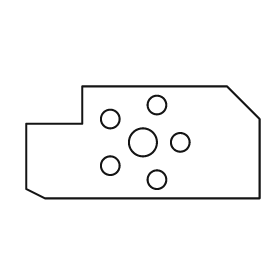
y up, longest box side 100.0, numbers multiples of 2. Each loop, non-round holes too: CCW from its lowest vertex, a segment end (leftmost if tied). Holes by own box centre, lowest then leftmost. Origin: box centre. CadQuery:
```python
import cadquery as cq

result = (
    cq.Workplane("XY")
    .moveTo(-42.0, -24.0)
    .lineTo(50.0, -24.0)
    .lineTo(50.0, 10.0)
    .lineTo(36.0, 24.0)
    .lineTo(-26.0, 24.0)
    .lineTo(-26.0, 8.0)
    .lineTo(-50.0, 8.0)
    .lineTo(-50.0, -20.0)
    .close()
    .moveTo(6.0, -16.0)
    .circle(4.0)
    .moveTo(-14.0, -10.0)
    .circle(4.0)
    .moveTo(0.0, 0.0)
    .circle(6.0)
    .moveTo(16.0, 0.0)
    .circle(4.0)
    .moveTo(-14.0, 10.0)
    .circle(4.0)
    .moveTo(6.0, 16.0)
    .circle(4.0)
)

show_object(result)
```